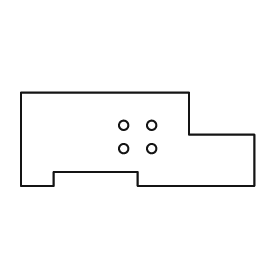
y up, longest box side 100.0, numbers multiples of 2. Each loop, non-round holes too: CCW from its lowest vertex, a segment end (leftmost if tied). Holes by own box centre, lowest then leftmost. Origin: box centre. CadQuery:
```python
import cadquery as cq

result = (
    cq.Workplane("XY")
    .moveTo(-50.0, -20.0)
    .lineTo(-36.0, -20.0)
    .lineTo(-36.0, -14.0)
    .lineTo(0.0, -14.0)
    .lineTo(0.0, -20.0)
    .lineTo(50.0, -20.0)
    .lineTo(50.0, 2.0)
    .lineTo(22.0, 2.0)
    .lineTo(22.0, 20.0)
    .lineTo(-50.0, 20.0)
    .close()
    .moveTo(-6.0, -4.0)
    .circle(2.0)
    .moveTo(6.0, -4.0)
    .circle(2.0)
    .moveTo(-6.0, 6.0)
    .circle(2.0)
    .moveTo(6.0, 6.0)
    .circle(2.0)
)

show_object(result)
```